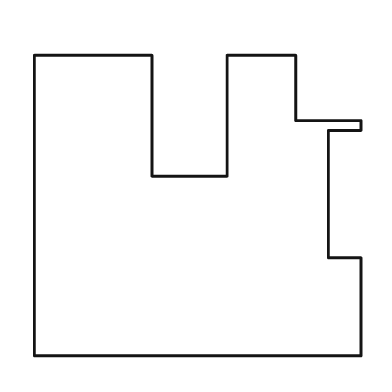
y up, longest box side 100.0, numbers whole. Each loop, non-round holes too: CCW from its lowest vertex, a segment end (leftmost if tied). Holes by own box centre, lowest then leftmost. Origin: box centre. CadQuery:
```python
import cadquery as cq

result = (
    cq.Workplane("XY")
    .moveTo(-50.0, -46.0)
    .lineTo(50.0, -46.0)
    .lineTo(50.0, -16.0)
    .lineTo(40.0, -16.0)
    .lineTo(40.0, 23.0)
    .lineTo(50.0, 23.0)
    .lineTo(50.0, 26.0)
    .lineTo(30.0, 26.0)
    .lineTo(30.0, 46.0)
    .lineTo(9.0, 46.0)
    .lineTo(9.0, 9.0)
    .lineTo(-14.0, 9.0)
    .lineTo(-14.0, 46.0)
    .lineTo(-50.0, 46.0)
    .close()
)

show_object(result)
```